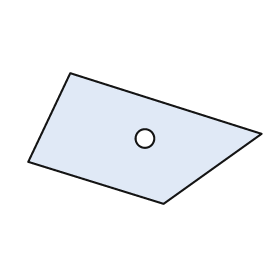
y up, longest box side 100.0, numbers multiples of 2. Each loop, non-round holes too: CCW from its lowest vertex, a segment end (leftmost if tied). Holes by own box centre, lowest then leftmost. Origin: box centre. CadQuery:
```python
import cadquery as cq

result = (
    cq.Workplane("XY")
    .moveTo(8.0, -28.0)
    .lineTo(50.0, 2.0)
    .lineTo(-32.0, 28.0)
    .lineTo(-50.0, -10.0)
    .close()
    .moveTo(0.0, 0.0)
    .circle(4.0)
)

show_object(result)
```